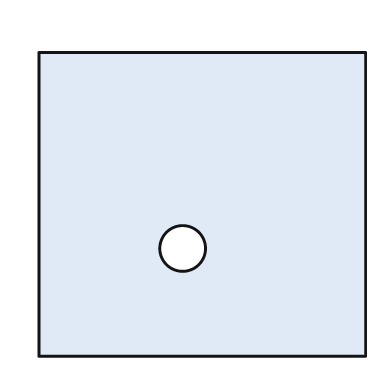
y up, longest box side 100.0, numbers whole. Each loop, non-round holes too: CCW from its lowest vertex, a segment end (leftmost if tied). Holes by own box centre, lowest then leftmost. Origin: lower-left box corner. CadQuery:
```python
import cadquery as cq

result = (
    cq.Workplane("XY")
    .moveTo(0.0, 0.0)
    .lineTo(100.0, 0.0)
    .lineTo(100.0, 93.0)
    .lineTo(0.0, 93.0)
    .close()
    .moveTo(44.0, 33.0)
    .circle(7.0)
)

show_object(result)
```